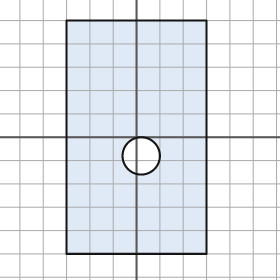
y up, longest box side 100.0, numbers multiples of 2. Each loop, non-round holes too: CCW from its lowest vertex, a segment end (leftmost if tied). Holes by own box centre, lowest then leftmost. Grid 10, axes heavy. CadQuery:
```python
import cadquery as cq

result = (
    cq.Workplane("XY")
    .moveTo(-30.0, -50.0)
    .lineTo(30.0, -50.0)
    .lineTo(30.0, 50.0)
    .lineTo(-30.0, 50.0)
    .close()
    .moveTo(2.0, -8.0)
    .circle(8.0)
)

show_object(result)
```